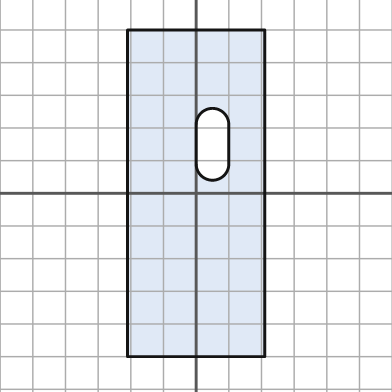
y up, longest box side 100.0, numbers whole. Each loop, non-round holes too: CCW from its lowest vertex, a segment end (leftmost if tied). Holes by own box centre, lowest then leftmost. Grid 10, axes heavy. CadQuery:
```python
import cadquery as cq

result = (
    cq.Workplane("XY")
    .moveTo(-21.0, -50.0)
    .lineTo(21.0, -50.0)
    .lineTo(21.0, 50.0)
    .lineTo(-21.0, 50.0)
    .close()
    .moveTo(0.0, 9.0)
    .threePointArc((5.0, 4.0), (10.0, 9.0))
    .lineTo(10.0, 21.0)
    .threePointArc((5.0, 26.0), (0.0, 21.0))
    .close()
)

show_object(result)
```